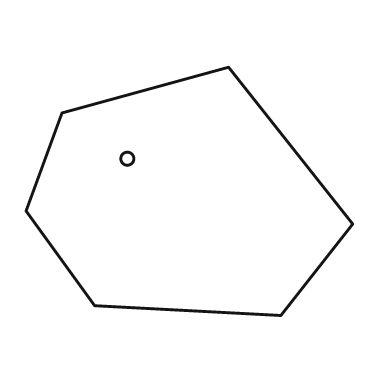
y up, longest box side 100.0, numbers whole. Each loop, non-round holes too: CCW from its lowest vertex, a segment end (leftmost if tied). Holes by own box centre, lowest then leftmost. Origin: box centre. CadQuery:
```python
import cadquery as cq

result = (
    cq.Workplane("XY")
    .moveTo(28.0, -38.0)
    .lineTo(50.0, -10.0)
    .lineTo(12.0, 38.0)
    .lineTo(-39.0, 24.0)
    .lineTo(-50.0, -6.0)
    .lineTo(-29.0, -35.0)
    .close()
    .moveTo(-19.0, 10.0)
    .circle(2.0)
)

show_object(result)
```